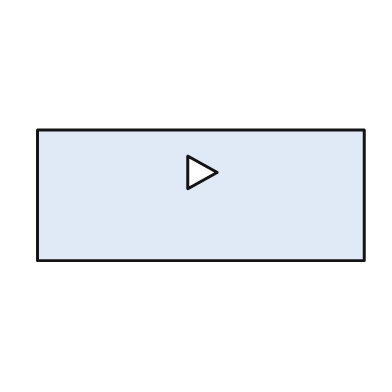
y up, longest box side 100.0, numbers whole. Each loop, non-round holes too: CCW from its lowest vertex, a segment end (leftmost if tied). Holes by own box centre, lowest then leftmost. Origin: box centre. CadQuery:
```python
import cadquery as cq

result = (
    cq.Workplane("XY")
    .moveTo(-50.0, -20.0)
    .lineTo(50.0, -20.0)
    .lineTo(50.0, 20.0)
    .lineTo(-50.0, 20.0)
    .close()
    .moveTo(-4.0, 2.0)
    .lineTo(5.0, 7.0)
    .lineTo(-4.0, 12.0)
    .close()
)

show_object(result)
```